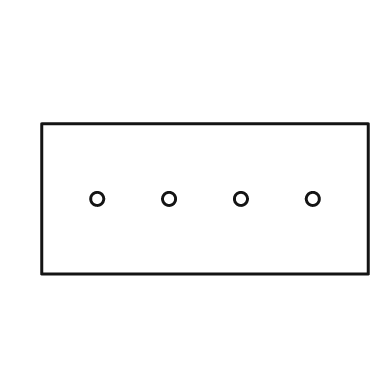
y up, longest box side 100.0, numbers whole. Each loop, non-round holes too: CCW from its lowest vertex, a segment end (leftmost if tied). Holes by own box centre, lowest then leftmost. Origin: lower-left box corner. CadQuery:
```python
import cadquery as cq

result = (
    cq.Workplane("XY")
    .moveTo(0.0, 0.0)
    .lineTo(100.0, 0.0)
    .lineTo(100.0, 46.0)
    .lineTo(0.0, 46.0)
    .close()
    .moveTo(17.0, 23.0)
    .circle(2.0)
    .moveTo(39.0, 23.0)
    .circle(2.0)
    .moveTo(61.0, 23.0)
    .circle(2.0)
    .moveTo(83.0, 23.0)
    .circle(2.0)
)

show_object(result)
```